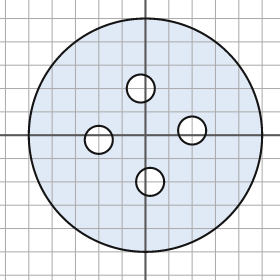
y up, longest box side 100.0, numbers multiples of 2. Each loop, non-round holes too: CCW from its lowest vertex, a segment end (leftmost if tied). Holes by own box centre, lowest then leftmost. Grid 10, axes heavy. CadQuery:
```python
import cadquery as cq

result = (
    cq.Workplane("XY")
    .moveTo(0.0, 0.0)
    .circle(50.0)
    .moveTo(2.0, -20.0)
    .circle(6.0)
    .moveTo(-20.0, -2.0)
    .circle(6.0)
    .moveTo(20.0, 2.0)
    .circle(6.0)
    .moveTo(-2.0, 20.0)
    .circle(6.0)
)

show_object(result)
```